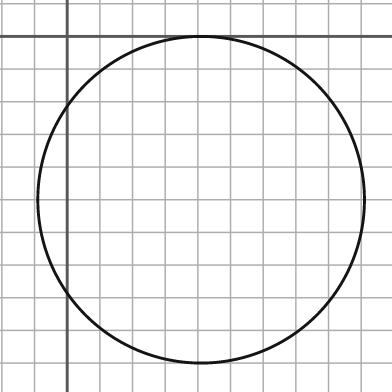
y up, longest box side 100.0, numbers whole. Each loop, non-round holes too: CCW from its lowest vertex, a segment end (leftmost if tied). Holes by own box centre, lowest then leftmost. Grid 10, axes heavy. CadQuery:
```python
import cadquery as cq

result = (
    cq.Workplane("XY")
    .moveTo(41.0, -50.0)
    .circle(50.0)
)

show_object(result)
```